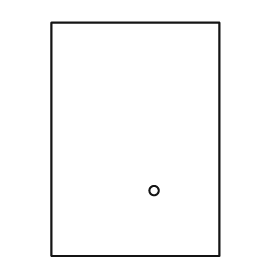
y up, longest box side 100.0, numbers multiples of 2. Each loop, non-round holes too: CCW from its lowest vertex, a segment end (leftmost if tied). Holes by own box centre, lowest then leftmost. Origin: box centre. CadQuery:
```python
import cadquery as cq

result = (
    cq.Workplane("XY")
    .moveTo(-36.0, -50.0)
    .lineTo(36.0, -50.0)
    .lineTo(36.0, 50.0)
    .lineTo(-36.0, 50.0)
    .close()
    .moveTo(8.0, -22.0)
    .circle(2.0)
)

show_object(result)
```